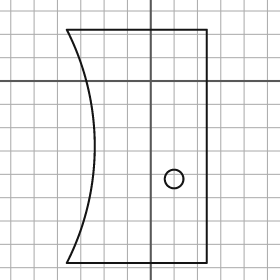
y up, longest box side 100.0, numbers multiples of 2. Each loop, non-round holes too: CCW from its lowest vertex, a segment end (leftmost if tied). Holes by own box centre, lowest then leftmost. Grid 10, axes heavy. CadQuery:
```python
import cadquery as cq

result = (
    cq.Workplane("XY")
    .moveTo(-36.0, -78.0)
    .lineTo(24.0, -78.0)
    .lineTo(24.0, 22.0)
    .lineTo(-36.0, 22.0)
    .threePointArc((-24.0, -28.0), (-36.0, -78.0))
    .close()
    .moveTo(10.0, -42.0)
    .circle(4.0)
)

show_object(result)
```